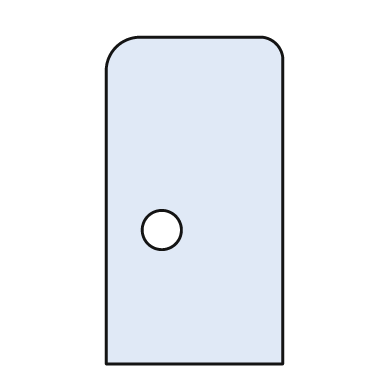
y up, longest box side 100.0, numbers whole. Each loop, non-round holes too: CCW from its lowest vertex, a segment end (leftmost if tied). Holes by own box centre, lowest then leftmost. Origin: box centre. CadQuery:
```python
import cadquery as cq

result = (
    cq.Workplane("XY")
    .moveTo(-27.0, -50.0)
    .lineTo(27.0, -50.0)
    .lineTo(27.0, 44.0)
    .threePointArc((25.0, 48.0), (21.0, 50.0))
    .lineTo(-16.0, 50.0)
    .threePointArc((-24.0, 47.0), (-27.0, 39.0))
    .close()
    .moveTo(-10.0, -9.0)
    .circle(6.0)
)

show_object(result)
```